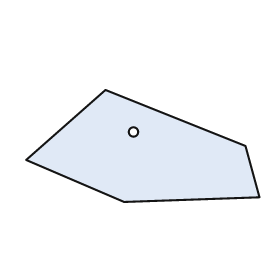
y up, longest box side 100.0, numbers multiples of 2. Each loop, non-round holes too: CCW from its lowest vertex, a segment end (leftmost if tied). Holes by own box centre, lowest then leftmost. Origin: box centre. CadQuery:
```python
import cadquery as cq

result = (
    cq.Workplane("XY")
    .moveTo(-8.0, -24.0)
    .lineTo(50.0, -22.0)
    .lineTo(44.0, 0.0)
    .lineTo(-16.0, 24.0)
    .lineTo(-50.0, -6.0)
    .close()
    .moveTo(-4.0, 6.0)
    .circle(2.0)
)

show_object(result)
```